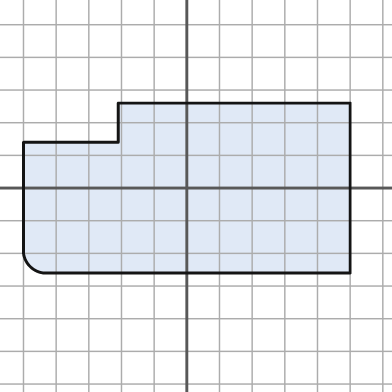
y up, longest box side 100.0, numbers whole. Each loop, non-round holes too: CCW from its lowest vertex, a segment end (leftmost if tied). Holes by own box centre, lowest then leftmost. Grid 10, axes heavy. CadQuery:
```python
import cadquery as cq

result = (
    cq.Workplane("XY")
    .moveTo(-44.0, -26.0)
    .lineTo(50.0, -26.0)
    .lineTo(50.0, 26.0)
    .lineTo(-21.0, 26.0)
    .lineTo(-21.0, 14.0)
    .lineTo(-50.0, 14.0)
    .lineTo(-50.0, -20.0)
    .threePointArc((-48.0, -24.0), (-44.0, -26.0))
    .close()
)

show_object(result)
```